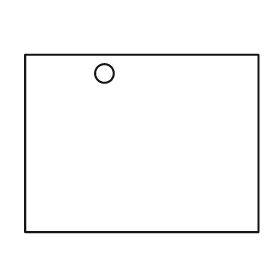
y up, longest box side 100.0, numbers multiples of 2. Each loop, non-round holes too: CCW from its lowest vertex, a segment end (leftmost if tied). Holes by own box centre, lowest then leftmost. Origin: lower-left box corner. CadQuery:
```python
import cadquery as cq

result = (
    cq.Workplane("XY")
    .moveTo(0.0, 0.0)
    .lineTo(100.0, 0.0)
    .lineTo(100.0, 76.0)
    .lineTo(0.0, 76.0)
    .close()
    .moveTo(34.0, 68.0)
    .circle(4.0)
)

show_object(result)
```